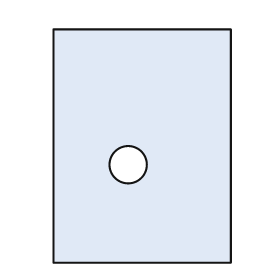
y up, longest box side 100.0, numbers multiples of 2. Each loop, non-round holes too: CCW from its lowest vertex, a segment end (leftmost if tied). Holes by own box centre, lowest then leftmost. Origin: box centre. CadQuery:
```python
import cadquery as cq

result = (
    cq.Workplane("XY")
    .moveTo(-38.0, -50.0)
    .lineTo(38.0, -50.0)
    .lineTo(38.0, 50.0)
    .lineTo(-38.0, 50.0)
    .close()
    .moveTo(-6.0, -8.0)
    .circle(8.0)
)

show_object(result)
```